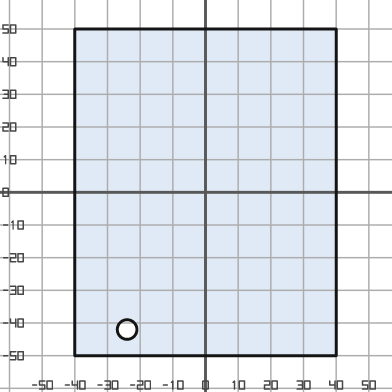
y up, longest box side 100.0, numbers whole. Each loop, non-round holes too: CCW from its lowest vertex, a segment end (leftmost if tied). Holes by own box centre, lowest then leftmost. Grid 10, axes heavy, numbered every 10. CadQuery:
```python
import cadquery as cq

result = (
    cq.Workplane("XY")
    .moveTo(-40.0, -50.0)
    .lineTo(40.0, -50.0)
    .lineTo(40.0, 50.0)
    .lineTo(-40.0, 50.0)
    .close()
    .moveTo(-24.0, -42.0)
    .circle(3.0)
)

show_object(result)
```